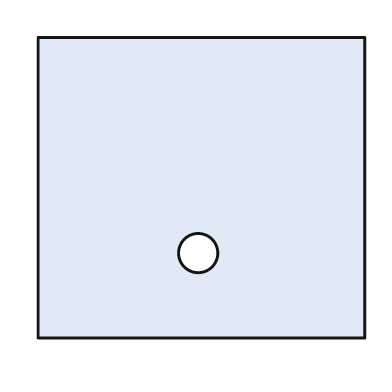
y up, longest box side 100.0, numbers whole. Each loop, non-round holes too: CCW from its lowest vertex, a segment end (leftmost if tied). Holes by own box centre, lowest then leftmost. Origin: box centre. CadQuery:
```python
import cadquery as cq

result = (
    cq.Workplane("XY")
    .moveTo(-50.0, -46.0)
    .lineTo(50.0, -46.0)
    .lineTo(50.0, 46.0)
    .lineTo(-50.0, 46.0)
    .close()
    .moveTo(-1.0, -20.0)
    .circle(6.0)
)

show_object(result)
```